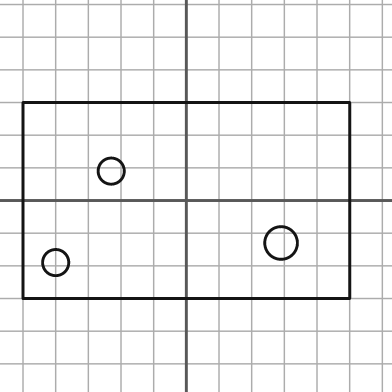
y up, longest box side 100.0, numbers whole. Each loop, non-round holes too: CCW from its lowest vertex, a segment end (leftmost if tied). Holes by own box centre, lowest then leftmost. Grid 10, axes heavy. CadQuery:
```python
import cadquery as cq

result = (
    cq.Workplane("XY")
    .moveTo(-50.0, -30.0)
    .lineTo(50.0, -30.0)
    .lineTo(50.0, 30.0)
    .lineTo(-50.0, 30.0)
    .close()
    .moveTo(-40.0, -19.0)
    .circle(4.0)
    .moveTo(29.0, -13.0)
    .circle(5.0)
    .moveTo(-23.0, 9.0)
    .circle(4.0)
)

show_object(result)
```